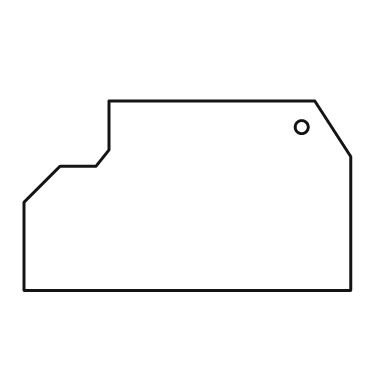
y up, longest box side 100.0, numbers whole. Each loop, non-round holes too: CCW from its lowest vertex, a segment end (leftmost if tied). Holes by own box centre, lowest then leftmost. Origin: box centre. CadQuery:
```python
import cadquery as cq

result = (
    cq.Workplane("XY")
    .moveTo(-50.0, -29.0)
    .lineTo(50.0, -29.0)
    .lineTo(50.0, 12.0)
    .lineTo(39.0, 29.0)
    .lineTo(-24.0, 29.0)
    .lineTo(-24.0, 14.0)
    .lineTo(-28.0, 9.0)
    .lineTo(-39.0, 9.0)
    .lineTo(-50.0, -2.0)
    .close()
    .moveTo(35.0, 21.0)
    .circle(2.0)
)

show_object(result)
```